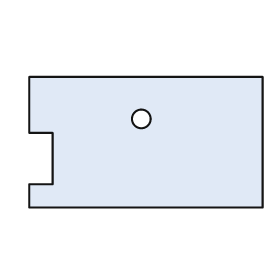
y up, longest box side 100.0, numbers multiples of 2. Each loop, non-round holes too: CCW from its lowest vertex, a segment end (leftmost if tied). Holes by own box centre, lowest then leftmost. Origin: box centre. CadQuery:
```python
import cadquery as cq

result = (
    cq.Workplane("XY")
    .moveTo(-50.0, -28.0)
    .lineTo(50.0, -28.0)
    .lineTo(50.0, 28.0)
    .lineTo(-50.0, 28.0)
    .lineTo(-50.0, 4.0)
    .lineTo(-40.0, 4.0)
    .lineTo(-40.0, -18.0)
    .lineTo(-50.0, -18.0)
    .close()
    .moveTo(-2.0, 10.0)
    .circle(4.0)
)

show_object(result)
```